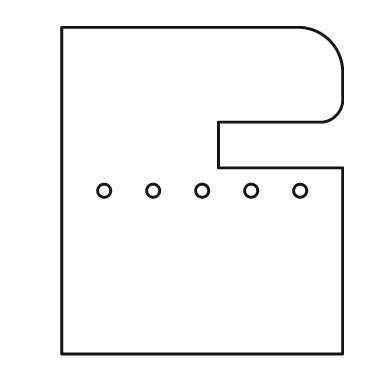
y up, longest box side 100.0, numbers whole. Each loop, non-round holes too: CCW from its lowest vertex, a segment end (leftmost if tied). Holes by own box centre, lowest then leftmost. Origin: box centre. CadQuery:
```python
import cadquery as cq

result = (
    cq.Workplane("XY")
    .moveTo(-43.0, -50.0)
    .lineTo(43.0, -50.0)
    .lineTo(43.0, 7.0)
    .lineTo(5.0, 7.0)
    .lineTo(5.0, 21.0)
    .lineTo(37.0, 21.0)
    .threePointArc((41.0, 23.0), (43.0, 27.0))
    .lineTo(43.0, 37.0)
    .threePointArc((39.0, 46.0), (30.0, 50.0))
    .lineTo(-43.0, 50.0)
    .close()
    .moveTo(-30.0, 0.0)
    .circle(2.0)
    .moveTo(-15.0, 0.0)
    .circle(2.0)
    .moveTo(0.0, 0.0)
    .circle(2.0)
    .moveTo(15.0, 0.0)
    .circle(2.0)
    .moveTo(30.0, 0.0)
    .circle(2.0)
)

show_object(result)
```